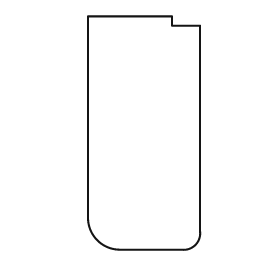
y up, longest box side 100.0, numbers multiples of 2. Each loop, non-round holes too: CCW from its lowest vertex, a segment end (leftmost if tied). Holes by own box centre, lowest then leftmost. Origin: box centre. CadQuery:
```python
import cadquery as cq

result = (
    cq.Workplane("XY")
    .moveTo(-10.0, -50.0)
    .lineTo(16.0, -50.0)
    .threePointArc((22.0, -48.0), (24.0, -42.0))
    .lineTo(24.0, 46.0)
    .lineTo(12.0, 46.0)
    .lineTo(12.0, 50.0)
    .lineTo(-24.0, 50.0)
    .lineTo(-24.0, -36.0)
    .threePointArc((-20.0, -46.0), (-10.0, -50.0))
    .close()
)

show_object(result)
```